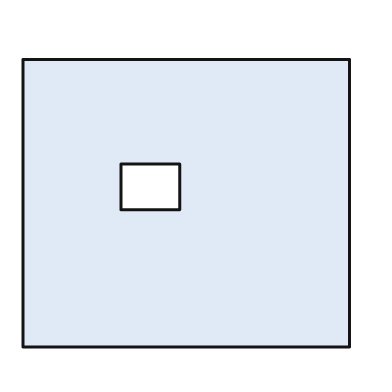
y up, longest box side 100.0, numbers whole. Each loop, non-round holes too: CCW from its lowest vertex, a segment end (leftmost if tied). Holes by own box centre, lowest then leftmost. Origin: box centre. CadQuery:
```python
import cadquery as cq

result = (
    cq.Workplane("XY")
    .moveTo(-50.0, -44.0)
    .lineTo(50.0, -44.0)
    .lineTo(50.0, 44.0)
    .lineTo(-50.0, 44.0)
    .close()
    .moveTo(-20.0, -2.0)
    .lineTo(-2.0, -2.0)
    .lineTo(-2.0, 12.0)
    .lineTo(-20.0, 12.0)
    .close()
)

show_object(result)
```